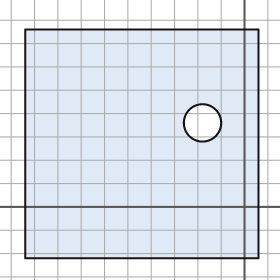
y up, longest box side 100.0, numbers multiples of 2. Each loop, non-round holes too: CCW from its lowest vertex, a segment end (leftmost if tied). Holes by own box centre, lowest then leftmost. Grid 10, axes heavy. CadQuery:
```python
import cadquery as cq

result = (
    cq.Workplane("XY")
    .moveTo(-94.0, -22.0)
    .lineTo(6.0, -22.0)
    .lineTo(6.0, 76.0)
    .lineTo(-94.0, 76.0)
    .close()
    .moveTo(-18.0, 36.0)
    .circle(8.0)
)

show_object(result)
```